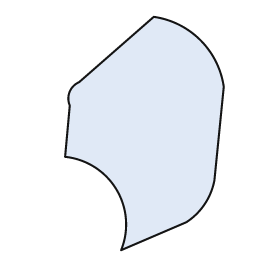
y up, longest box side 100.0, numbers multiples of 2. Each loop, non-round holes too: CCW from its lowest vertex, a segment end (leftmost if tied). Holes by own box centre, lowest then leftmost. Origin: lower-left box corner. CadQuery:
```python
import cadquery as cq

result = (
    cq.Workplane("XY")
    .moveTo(24.0, 0.0)
    .lineTo(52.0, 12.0)
    .threePointArc((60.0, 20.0), (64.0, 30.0))
    .lineTo(68.0, 70.0)
    .threePointArc((58.0, 90.0), (38.0, 100.0))
    .lineTo(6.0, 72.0)
    .threePointArc((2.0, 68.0), (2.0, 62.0))
    .lineTo(0.0, 40.0)
    .threePointArc((22.0, 26.0), (24.0, 0.0))
    .close()
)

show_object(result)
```